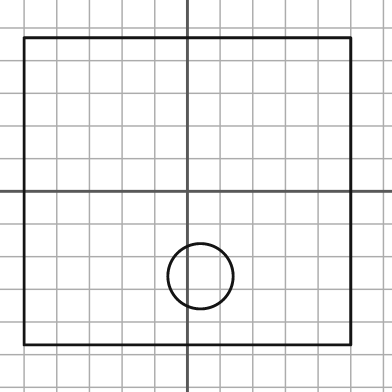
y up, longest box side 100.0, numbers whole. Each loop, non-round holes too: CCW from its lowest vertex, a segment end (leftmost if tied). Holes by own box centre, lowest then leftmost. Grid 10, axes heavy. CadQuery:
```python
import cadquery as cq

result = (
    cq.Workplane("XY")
    .moveTo(-50.0, -47.0)
    .lineTo(50.0, -47.0)
    .lineTo(50.0, 47.0)
    .lineTo(-50.0, 47.0)
    .close()
    .moveTo(4.0, -26.0)
    .circle(10.0)
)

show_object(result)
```